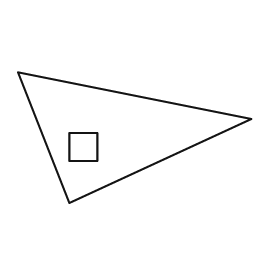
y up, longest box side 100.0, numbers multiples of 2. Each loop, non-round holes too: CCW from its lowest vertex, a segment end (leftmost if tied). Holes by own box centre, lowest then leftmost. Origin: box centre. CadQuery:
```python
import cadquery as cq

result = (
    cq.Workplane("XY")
    .moveTo(-28.0, -28.0)
    .lineTo(50.0, 8.0)
    .lineTo(-50.0, 28.0)
    .close()
    .moveTo(-28.0, -10.0)
    .lineTo(-16.0, -10.0)
    .lineTo(-16.0, 2.0)
    .lineTo(-28.0, 2.0)
    .close()
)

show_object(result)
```